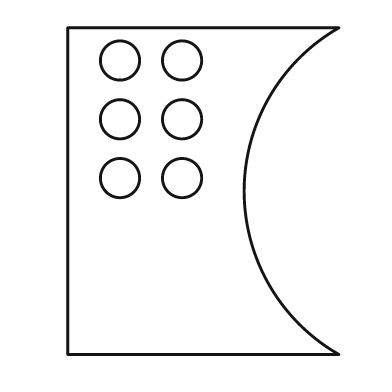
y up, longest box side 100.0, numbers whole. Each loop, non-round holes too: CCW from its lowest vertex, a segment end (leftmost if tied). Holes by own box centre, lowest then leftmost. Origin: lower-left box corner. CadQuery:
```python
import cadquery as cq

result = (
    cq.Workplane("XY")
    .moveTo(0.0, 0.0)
    .lineTo(83.0, 0.0)
    .threePointArc((54.0, 50.0), (83.0, 100.0))
    .lineTo(0.0, 100.0)
    .close()
    .moveTo(16.0, 54.0)
    .circle(6.0)
    .moveTo(35.0, 54.0)
    .circle(6.0)
    .moveTo(16.0, 72.0)
    .circle(6.0)
    .moveTo(35.0, 72.0)
    .circle(6.0)
    .moveTo(16.0, 90.0)
    .circle(6.0)
    .moveTo(35.0, 90.0)
    .circle(6.0)
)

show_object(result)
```